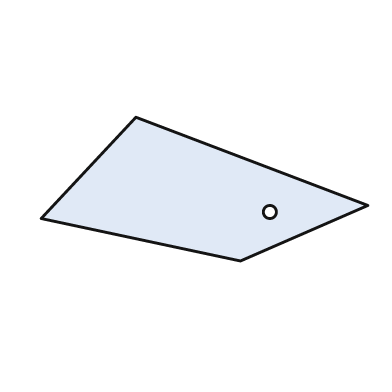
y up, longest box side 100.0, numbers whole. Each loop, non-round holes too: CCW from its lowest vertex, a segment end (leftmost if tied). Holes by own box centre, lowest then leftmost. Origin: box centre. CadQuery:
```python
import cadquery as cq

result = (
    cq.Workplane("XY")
    .moveTo(11.0, -22.0)
    .lineTo(50.0, -5.0)
    .lineTo(-21.0, 22.0)
    .lineTo(-50.0, -9.0)
    .close()
    .moveTo(20.0, -7.0)
    .circle(2.0)
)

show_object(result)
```